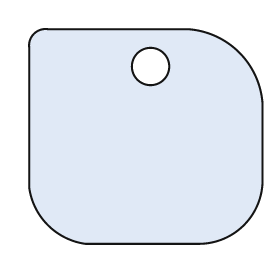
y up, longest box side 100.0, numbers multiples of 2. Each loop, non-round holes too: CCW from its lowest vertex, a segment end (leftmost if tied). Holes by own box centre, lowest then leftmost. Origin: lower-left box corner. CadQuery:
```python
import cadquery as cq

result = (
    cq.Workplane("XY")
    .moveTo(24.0, 0.0)
    .lineTo(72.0, 0.0)
    .threePointArc((92.0, 8.0), (100.0, 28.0))
    .lineTo(100.0, 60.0)
    .threePointArc((90.0, 82.0), (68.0, 92.0))
    .lineTo(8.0, 92.0)
    .threePointArc((2.0, 90.0), (0.0, 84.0))
    .lineTo(0.0, 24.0)
    .threePointArc((8.0, 8.0), (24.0, 0.0))
    .close()
    .moveTo(52.0, 76.0)
    .circle(8.0)
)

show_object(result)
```